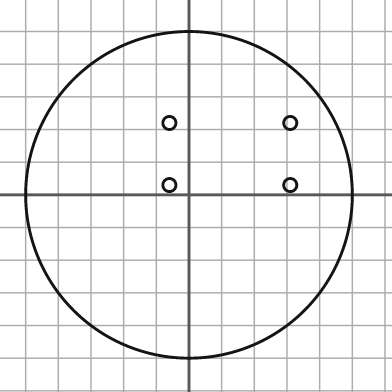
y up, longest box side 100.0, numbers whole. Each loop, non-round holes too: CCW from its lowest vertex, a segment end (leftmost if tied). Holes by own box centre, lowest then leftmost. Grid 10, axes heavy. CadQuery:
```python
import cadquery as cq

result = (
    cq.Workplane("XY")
    .moveTo(0.0, 0.0)
    .circle(50.0)
    .moveTo(-6.0, 3.0)
    .circle(2.0)
    .moveTo(31.0, 3.0)
    .circle(2.0)
    .moveTo(-6.0, 22.0)
    .circle(2.0)
    .moveTo(31.0, 22.0)
    .circle(2.0)
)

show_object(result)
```